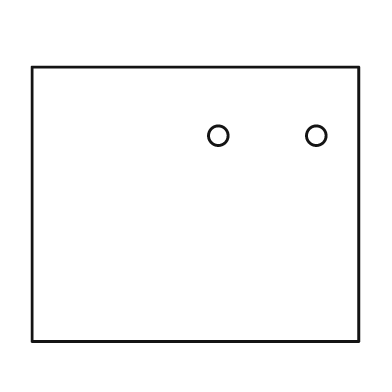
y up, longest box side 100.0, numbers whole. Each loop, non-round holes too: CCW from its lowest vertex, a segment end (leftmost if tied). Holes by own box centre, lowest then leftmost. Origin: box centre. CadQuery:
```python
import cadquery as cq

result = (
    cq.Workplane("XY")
    .moveTo(-50.0, -42.0)
    .lineTo(50.0, -42.0)
    .lineTo(50.0, 42.0)
    .lineTo(-50.0, 42.0)
    .close()
    .moveTo(7.0, 21.0)
    .circle(3.0)
    .moveTo(37.0, 21.0)
    .circle(3.0)
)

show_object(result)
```